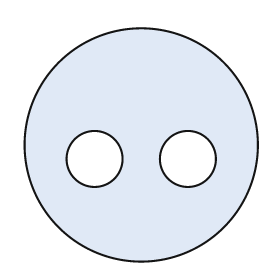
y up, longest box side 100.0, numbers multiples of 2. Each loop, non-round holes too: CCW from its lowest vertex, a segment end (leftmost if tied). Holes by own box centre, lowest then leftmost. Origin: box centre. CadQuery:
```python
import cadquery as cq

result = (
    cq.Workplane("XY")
    .moveTo(0.0, 0.0)
    .circle(50.0)
    .moveTo(-20.0, -6.0)
    .circle(12.0)
    .moveTo(20.0, -6.0)
    .circle(12.0)
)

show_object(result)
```